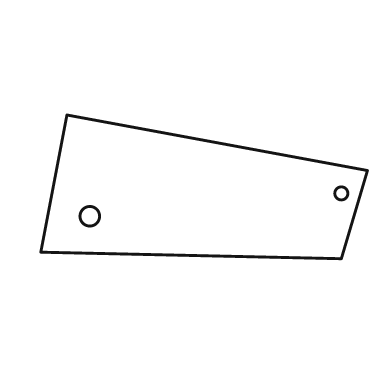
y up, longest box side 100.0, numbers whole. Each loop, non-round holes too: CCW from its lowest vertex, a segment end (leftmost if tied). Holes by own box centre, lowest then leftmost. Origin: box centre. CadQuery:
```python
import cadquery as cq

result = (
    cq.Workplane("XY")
    .moveTo(42.0, -22.0)
    .lineTo(50.0, 5.0)
    .lineTo(-42.0, 22.0)
    .lineTo(-50.0, -20.0)
    .close()
    .moveTo(-35.0, -9.0)
    .circle(3.0)
    .moveTo(42.0, -2.0)
    .circle(2.0)
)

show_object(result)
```